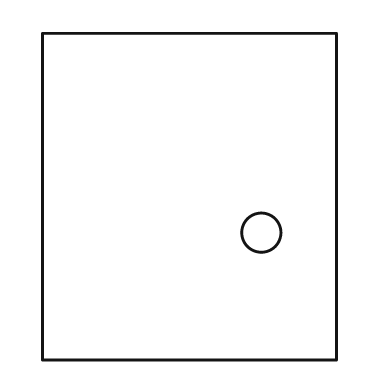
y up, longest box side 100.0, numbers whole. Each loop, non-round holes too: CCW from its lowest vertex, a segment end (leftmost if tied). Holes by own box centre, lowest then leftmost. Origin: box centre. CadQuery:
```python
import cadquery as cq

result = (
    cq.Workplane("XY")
    .moveTo(-45.0, -50.0)
    .lineTo(45.0, -50.0)
    .lineTo(45.0, 50.0)
    .lineTo(-45.0, 50.0)
    .close()
    .moveTo(22.0, -11.0)
    .circle(6.0)
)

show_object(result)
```